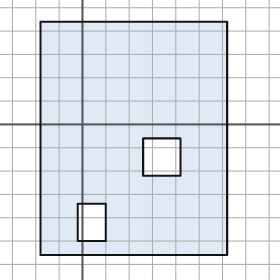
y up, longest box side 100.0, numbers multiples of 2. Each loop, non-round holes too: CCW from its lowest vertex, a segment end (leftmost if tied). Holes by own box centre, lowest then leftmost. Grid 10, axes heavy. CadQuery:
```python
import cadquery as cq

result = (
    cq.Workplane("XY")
    .moveTo(-18.0, -56.0)
    .lineTo(62.0, -56.0)
    .lineTo(62.0, 44.0)
    .lineTo(-18.0, 44.0)
    .close()
    .moveTo(-2.0, -50.0)
    .lineTo(10.0, -50.0)
    .lineTo(10.0, -34.0)
    .lineTo(-2.0, -34.0)
    .close()
    .moveTo(26.0, -22.0)
    .lineTo(42.0, -22.0)
    .lineTo(42.0, -6.0)
    .lineTo(26.0, -6.0)
    .close()
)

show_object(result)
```